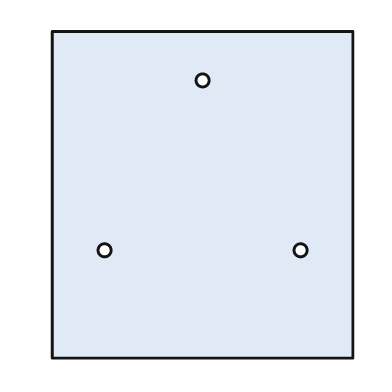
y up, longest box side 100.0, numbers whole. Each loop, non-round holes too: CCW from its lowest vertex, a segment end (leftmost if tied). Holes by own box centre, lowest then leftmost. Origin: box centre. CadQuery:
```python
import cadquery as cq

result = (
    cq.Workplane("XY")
    .moveTo(-46.0, -50.0)
    .lineTo(46.0, -50.0)
    .lineTo(46.0, 50.0)
    .lineTo(-46.0, 50.0)
    .close()
    .moveTo(-30.0, -17.0)
    .circle(2.0)
    .moveTo(30.0, -17.0)
    .circle(2.0)
    .moveTo(0.0, 35.0)
    .circle(2.0)
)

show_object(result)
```